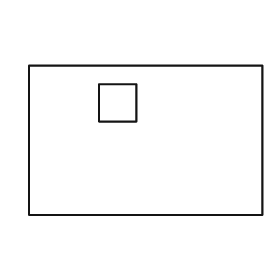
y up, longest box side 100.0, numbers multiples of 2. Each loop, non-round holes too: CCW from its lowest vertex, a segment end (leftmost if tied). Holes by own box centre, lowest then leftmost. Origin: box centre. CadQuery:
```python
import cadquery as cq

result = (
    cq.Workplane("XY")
    .moveTo(-50.0, -32.0)
    .lineTo(50.0, -32.0)
    .lineTo(50.0, 32.0)
    .lineTo(-50.0, 32.0)
    .close()
    .moveTo(-20.0, 8.0)
    .lineTo(-4.0, 8.0)
    .lineTo(-4.0, 24.0)
    .lineTo(-20.0, 24.0)
    .close()
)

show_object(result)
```